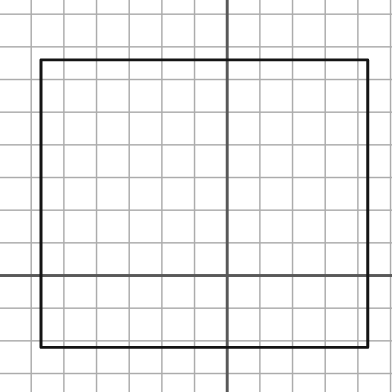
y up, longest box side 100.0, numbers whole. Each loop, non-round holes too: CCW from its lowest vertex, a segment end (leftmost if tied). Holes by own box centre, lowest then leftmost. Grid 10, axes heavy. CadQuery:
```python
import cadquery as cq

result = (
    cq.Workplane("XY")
    .moveTo(-57.0, -22.0)
    .lineTo(43.0, -22.0)
    .lineTo(43.0, 66.0)
    .lineTo(-57.0, 66.0)
    .close()
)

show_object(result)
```